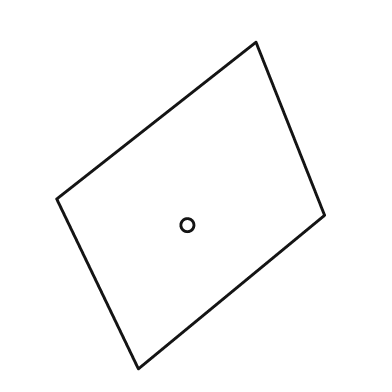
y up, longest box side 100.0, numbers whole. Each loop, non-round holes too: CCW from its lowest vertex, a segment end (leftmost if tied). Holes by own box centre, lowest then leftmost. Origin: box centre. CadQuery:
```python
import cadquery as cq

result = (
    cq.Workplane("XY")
    .moveTo(-16.0, -50.0)
    .lineTo(41.0, -3.0)
    .lineTo(20.0, 50.0)
    .lineTo(-41.0, 2.0)
    .close()
    .moveTo(-1.0, -6.0)
    .circle(2.0)
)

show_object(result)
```